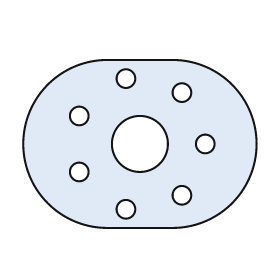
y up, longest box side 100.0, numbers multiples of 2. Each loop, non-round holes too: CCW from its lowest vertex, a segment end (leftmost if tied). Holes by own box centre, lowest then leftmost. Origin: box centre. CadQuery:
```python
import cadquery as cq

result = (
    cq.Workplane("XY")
    .moveTo(-14.0, -36.0)
    .lineTo(14.0, -36.0)
    .threePointArc((50.0, 0.0), (14.0, 36.0))
    .lineTo(-14.0, 36.0)
    .threePointArc((-50.0, 0.0), (-14.0, -36.0))
    .close()
    .moveTo(-6.0, -28.0)
    .circle(4.0)
    .moveTo(18.0, -22.0)
    .circle(4.0)
    .moveTo(-26.0, -12.0)
    .circle(4.0)
    .moveTo(0.0, 0.0)
    .circle(12.0)
    .moveTo(28.0, 0.0)
    .circle(4.0)
    .moveTo(-26.0, 12.0)
    .circle(4.0)
    .moveTo(18.0, 22.0)
    .circle(4.0)
    .moveTo(-6.0, 28.0)
    .circle(4.0)
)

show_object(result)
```